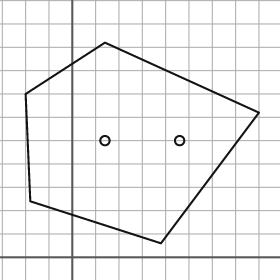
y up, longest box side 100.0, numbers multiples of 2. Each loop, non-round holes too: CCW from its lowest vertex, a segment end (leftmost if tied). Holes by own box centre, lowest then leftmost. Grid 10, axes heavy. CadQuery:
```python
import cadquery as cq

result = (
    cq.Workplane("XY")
    .moveTo(38.0, 6.0)
    .lineTo(80.0, 62.0)
    .lineTo(14.0, 92.0)
    .lineTo(-20.0, 70.0)
    .lineTo(-18.0, 24.0)
    .close()
    .moveTo(14.0, 50.0)
    .circle(2.0)
    .moveTo(46.0, 50.0)
    .circle(2.0)
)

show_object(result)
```